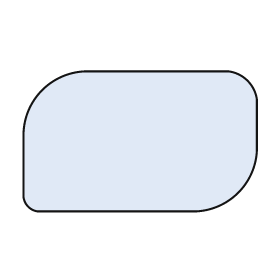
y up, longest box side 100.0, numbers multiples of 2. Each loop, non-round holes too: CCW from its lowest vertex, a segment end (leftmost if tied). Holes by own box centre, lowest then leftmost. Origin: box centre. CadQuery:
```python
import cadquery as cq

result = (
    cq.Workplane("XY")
    .moveTo(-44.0, -30.0)
    .lineTo(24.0, -30.0)
    .threePointArc((42.0, -22.0), (50.0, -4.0))
    .lineTo(50.0, 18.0)
    .threePointArc((46.0, 26.0), (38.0, 30.0))
    .lineTo(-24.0, 30.0)
    .threePointArc((-42.0, 22.0), (-50.0, 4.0))
    .lineTo(-50.0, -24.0)
    .threePointArc((-48.0, -28.0), (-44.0, -30.0))
    .close()
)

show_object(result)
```